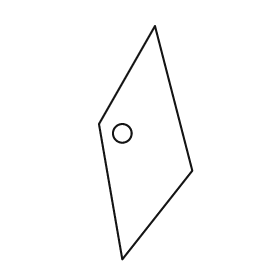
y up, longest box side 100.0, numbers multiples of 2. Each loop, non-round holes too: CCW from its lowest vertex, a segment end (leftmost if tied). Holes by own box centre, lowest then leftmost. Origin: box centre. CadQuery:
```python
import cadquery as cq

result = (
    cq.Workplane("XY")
    .moveTo(-10.0, -50.0)
    .lineTo(20.0, -12.0)
    .lineTo(4.0, 50.0)
    .lineTo(-20.0, 8.0)
    .close()
    .moveTo(-10.0, 4.0)
    .circle(4.0)
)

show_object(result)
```